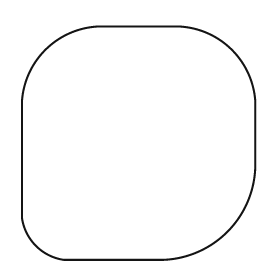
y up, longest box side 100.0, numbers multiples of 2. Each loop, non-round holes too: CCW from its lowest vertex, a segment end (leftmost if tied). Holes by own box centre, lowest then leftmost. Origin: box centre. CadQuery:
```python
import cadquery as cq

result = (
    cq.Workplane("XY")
    .moveTo(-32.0, -50.0)
    .lineTo(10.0, -50.0)
    .threePointArc((38.0, -38.0), (50.0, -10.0))
    .lineTo(50.0, 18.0)
    .threePointArc((40.0, 40.0), (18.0, 50.0))
    .lineTo(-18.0, 50.0)
    .threePointArc((-40.0, 40.0), (-50.0, 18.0))
    .lineTo(-50.0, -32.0)
    .threePointArc((-44.0, -44.0), (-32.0, -50.0))
    .close()
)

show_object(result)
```